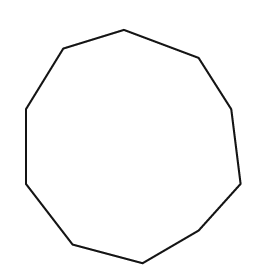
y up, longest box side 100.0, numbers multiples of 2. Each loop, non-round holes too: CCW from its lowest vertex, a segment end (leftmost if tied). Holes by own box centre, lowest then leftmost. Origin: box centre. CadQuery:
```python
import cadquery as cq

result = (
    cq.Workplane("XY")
    .moveTo(4.0, -50.0)
    .lineTo(28.0, -36.0)
    .lineTo(46.0, -16.0)
    .lineTo(42.0, 16.0)
    .lineTo(28.0, 38.0)
    .lineTo(-4.0, 50.0)
    .lineTo(-30.0, 42.0)
    .lineTo(-46.0, 16.0)
    .lineTo(-46.0, -16.0)
    .lineTo(-26.0, -42.0)
    .close()
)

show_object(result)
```